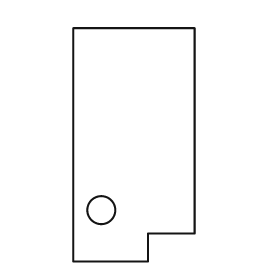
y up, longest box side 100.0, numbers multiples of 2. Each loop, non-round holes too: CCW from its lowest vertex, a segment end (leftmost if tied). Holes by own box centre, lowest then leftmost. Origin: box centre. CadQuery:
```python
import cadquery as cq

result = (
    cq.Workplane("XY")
    .moveTo(-26.0, -50.0)
    .lineTo(6.0, -50.0)
    .lineTo(6.0, -38.0)
    .lineTo(26.0, -38.0)
    .lineTo(26.0, 50.0)
    .lineTo(-26.0, 50.0)
    .close()
    .moveTo(-14.0, -28.0)
    .circle(6.0)
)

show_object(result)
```